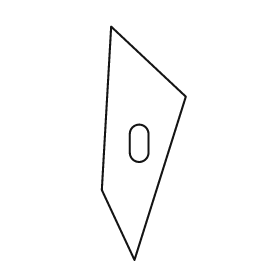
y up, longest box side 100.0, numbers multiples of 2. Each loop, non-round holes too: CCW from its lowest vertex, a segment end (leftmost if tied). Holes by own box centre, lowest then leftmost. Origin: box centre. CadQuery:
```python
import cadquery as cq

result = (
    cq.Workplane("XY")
    .moveTo(-4.0, -50.0)
    .lineTo(18.0, 20.0)
    .lineTo(-14.0, 50.0)
    .lineTo(-18.0, -20.0)
    .close()
    .moveTo(-6.0, -4.0)
    .threePointArc((-2.0, -8.0), (2.0, -4.0))
    .lineTo(2.0, 4.0)
    .threePointArc((-2.0, 8.0), (-6.0, 4.0))
    .close()
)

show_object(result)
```